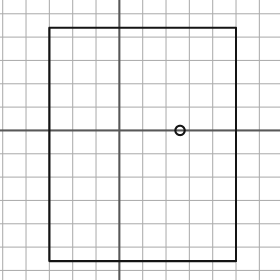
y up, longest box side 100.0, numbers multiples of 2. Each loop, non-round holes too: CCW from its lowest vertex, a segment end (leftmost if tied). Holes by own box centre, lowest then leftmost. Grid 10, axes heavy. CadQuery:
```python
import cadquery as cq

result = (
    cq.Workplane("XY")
    .moveTo(-30.0, -56.0)
    .lineTo(50.0, -56.0)
    .lineTo(50.0, 44.0)
    .lineTo(-30.0, 44.0)
    .close()
    .moveTo(26.0, 0.0)
    .circle(2.0)
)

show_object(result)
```